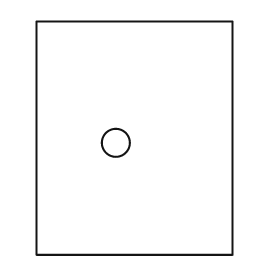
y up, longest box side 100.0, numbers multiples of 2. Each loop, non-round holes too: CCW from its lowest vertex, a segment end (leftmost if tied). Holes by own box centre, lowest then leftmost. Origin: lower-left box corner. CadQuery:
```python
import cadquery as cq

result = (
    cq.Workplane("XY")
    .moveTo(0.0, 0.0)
    .lineTo(84.0, 0.0)
    .lineTo(84.0, 100.0)
    .lineTo(0.0, 100.0)
    .close()
    .moveTo(34.0, 48.0)
    .circle(6.0)
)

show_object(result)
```